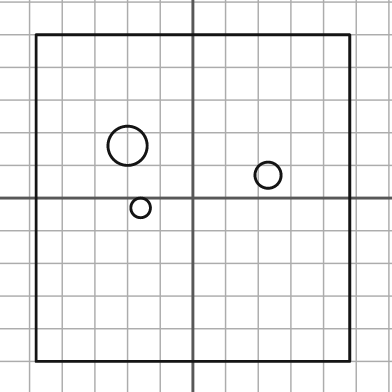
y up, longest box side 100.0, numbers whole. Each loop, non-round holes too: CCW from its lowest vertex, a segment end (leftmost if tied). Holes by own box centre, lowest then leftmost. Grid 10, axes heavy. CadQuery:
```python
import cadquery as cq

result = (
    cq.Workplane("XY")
    .moveTo(-48.0, -50.0)
    .lineTo(48.0, -50.0)
    .lineTo(48.0, 50.0)
    .lineTo(-48.0, 50.0)
    .close()
    .moveTo(-16.0, -3.0)
    .circle(3.0)
    .moveTo(23.0, 7.0)
    .circle(4.0)
    .moveTo(-20.0, 16.0)
    .circle(6.0)
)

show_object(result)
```